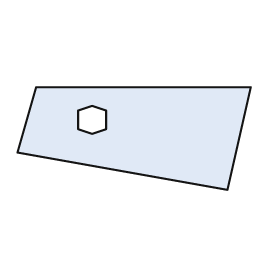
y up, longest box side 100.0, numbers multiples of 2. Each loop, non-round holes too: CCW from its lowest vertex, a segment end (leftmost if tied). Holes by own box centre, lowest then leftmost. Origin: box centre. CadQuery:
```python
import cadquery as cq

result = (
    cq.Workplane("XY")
    .moveTo(40.0, -22.0)
    .lineTo(50.0, 22.0)
    .lineTo(-42.0, 22.0)
    .lineTo(-50.0, -6.0)
    .close()
    .moveTo(-18.0, 2.0)
    .lineTo(-12.0, 4.0)
    .lineTo(-12.0, 12.0)
    .lineTo(-18.0, 14.0)
    .lineTo(-24.0, 12.0)
    .lineTo(-24.0, 4.0)
    .close()
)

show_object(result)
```